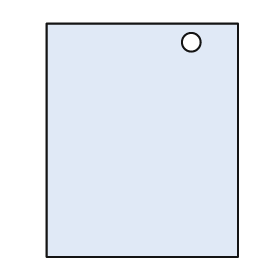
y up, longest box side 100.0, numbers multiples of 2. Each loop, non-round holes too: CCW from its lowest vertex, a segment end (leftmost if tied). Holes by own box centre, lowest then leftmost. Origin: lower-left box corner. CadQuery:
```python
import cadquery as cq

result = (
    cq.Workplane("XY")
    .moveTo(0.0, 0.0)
    .lineTo(82.0, 0.0)
    .lineTo(82.0, 100.0)
    .lineTo(0.0, 100.0)
    .close()
    .moveTo(62.0, 92.0)
    .circle(4.0)
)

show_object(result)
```